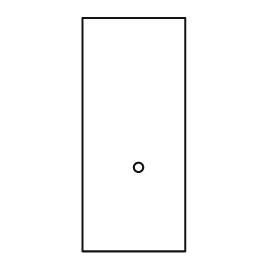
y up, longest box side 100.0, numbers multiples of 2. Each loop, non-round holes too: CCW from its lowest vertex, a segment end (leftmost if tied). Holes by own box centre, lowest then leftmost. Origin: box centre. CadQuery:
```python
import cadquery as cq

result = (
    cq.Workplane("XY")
    .moveTo(-22.0, -50.0)
    .lineTo(22.0, -50.0)
    .lineTo(22.0, 50.0)
    .lineTo(-22.0, 50.0)
    .close()
    .moveTo(2.0, -14.0)
    .circle(2.0)
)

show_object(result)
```